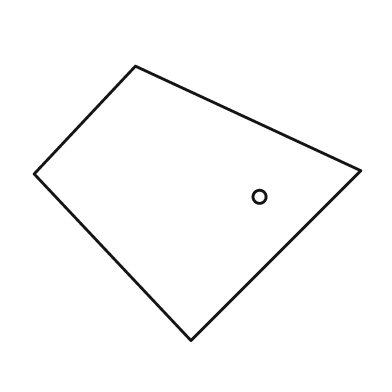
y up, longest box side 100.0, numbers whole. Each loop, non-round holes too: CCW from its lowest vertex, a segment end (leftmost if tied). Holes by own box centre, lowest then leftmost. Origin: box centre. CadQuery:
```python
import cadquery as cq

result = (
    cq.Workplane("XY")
    .moveTo(-2.0, -42.0)
    .lineTo(50.0, 10.0)
    .lineTo(-19.0, 42.0)
    .lineTo(-50.0, 9.0)
    .close()
    .moveTo(19.0, 2.0)
    .circle(2.0)
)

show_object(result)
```